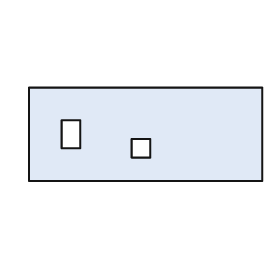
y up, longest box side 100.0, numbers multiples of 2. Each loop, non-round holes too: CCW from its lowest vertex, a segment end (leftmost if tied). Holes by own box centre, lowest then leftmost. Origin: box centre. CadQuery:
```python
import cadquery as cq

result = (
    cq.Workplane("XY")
    .moveTo(-50.0, -20.0)
    .lineTo(50.0, -20.0)
    .lineTo(50.0, 20.0)
    .lineTo(-50.0, 20.0)
    .close()
    .moveTo(-6.0, -10.0)
    .lineTo(2.0, -10.0)
    .lineTo(2.0, -2.0)
    .lineTo(-6.0, -2.0)
    .close()
    .moveTo(-36.0, -6.0)
    .lineTo(-28.0, -6.0)
    .lineTo(-28.0, 6.0)
    .lineTo(-36.0, 6.0)
    .close()
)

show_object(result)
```